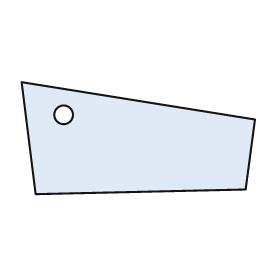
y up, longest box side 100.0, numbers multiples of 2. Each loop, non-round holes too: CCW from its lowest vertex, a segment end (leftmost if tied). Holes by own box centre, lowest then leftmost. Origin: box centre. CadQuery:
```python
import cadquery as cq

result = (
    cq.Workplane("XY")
    .moveTo(-44.0, -24.0)
    .lineTo(46.0, -22.0)
    .lineTo(50.0, 8.0)
    .lineTo(-50.0, 24.0)
    .close()
    .moveTo(-32.0, 10.0)
    .circle(4.0)
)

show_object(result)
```